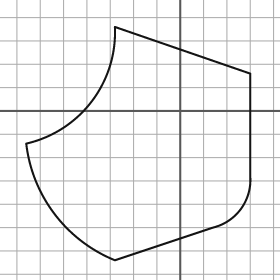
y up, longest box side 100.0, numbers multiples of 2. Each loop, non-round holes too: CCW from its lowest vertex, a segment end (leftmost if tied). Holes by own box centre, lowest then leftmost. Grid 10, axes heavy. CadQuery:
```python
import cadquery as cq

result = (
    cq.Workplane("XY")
    .moveTo(-28.0, -64.0)
    .lineTo(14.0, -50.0)
    .threePointArc((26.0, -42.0), (30.0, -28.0))
    .lineTo(30.0, 16.0)
    .lineTo(-28.0, 36.0)
    .threePointArc((-38.0, 4.0), (-66.0, -14.0))
    .threePointArc((-54.0, -44.0), (-28.0, -64.0))
    .close()
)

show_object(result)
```